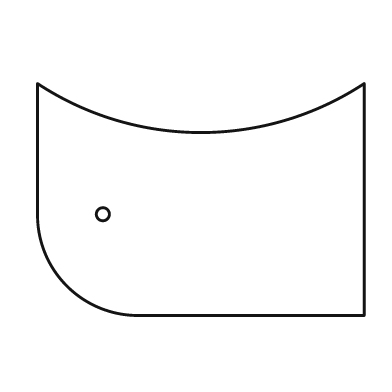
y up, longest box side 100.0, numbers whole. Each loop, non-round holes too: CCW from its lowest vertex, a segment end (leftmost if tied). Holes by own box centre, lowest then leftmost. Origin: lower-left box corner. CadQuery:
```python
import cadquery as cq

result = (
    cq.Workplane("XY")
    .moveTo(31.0, 0.0)
    .lineTo(100.0, 0.0)
    .lineTo(100.0, 71.0)
    .threePointArc((50.0, 56.0), (0.0, 71.0))
    .lineTo(0.0, 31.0)
    .threePointArc((9.0, 9.0), (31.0, 0.0))
    .close()
    .moveTo(20.0, 31.0)
    .circle(2.0)
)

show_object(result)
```